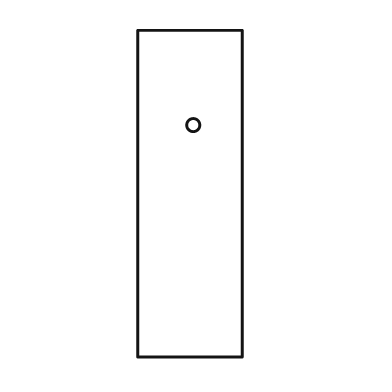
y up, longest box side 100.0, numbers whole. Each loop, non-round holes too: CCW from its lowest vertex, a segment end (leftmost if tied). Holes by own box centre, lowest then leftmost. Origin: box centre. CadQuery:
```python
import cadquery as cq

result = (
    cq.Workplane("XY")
    .moveTo(-16.0, -50.0)
    .lineTo(16.0, -50.0)
    .lineTo(16.0, 50.0)
    .lineTo(-16.0, 50.0)
    .close()
    .moveTo(1.0, 21.0)
    .circle(2.0)
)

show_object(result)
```